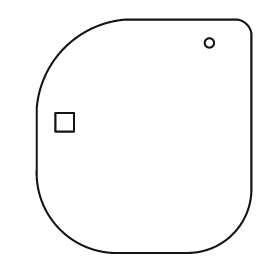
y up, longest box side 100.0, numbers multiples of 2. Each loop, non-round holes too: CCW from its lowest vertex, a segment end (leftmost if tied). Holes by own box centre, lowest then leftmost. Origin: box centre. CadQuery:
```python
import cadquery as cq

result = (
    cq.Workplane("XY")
    .moveTo(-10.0, -50.0)
    .lineTo(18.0, -50.0)
    .threePointArc((38.0, -42.0), (46.0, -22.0))
    .lineTo(46.0, 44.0)
    .threePointArc((44.0, 48.0), (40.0, 50.0))
    .lineTo(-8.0, 50.0)
    .threePointArc((-34.0, 38.0), (-46.0, 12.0))
    .lineTo(-46.0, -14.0)
    .threePointArc((-36.0, -40.0), (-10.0, -50.0))
    .close()
    .moveTo(-38.0, 2.0)
    .lineTo(-30.0, 2.0)
    .lineTo(-30.0, 10.0)
    .lineTo(-38.0, 10.0)
    .close()
    .moveTo(28.0, 40.0)
    .circle(2.0)
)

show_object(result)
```